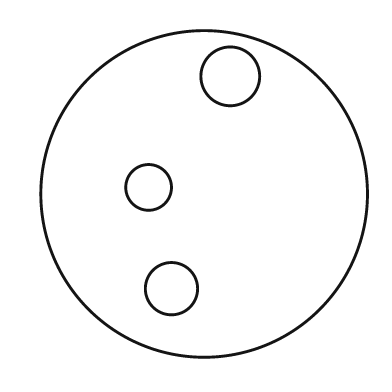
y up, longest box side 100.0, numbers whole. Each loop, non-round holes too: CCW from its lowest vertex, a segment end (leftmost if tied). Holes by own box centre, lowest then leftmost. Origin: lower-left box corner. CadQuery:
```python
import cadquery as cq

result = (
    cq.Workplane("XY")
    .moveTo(50.0, 50.0)
    .circle(50.0)
    .moveTo(40.0, 21.0)
    .circle(8.0)
    .moveTo(33.0, 52.0)
    .circle(7.0)
    .moveTo(58.0, 86.0)
    .circle(9.0)
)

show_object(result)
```